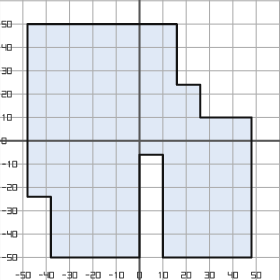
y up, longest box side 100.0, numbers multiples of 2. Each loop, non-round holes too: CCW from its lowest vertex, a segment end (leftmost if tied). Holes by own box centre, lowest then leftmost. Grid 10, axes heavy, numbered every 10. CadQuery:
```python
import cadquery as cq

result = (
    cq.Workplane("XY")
    .moveTo(-38.0, -50.0)
    .lineTo(0.0, -50.0)
    .lineTo(0.0, -6.0)
    .lineTo(10.0, -6.0)
    .lineTo(10.0, -50.0)
    .lineTo(48.0, -50.0)
    .lineTo(48.0, 10.0)
    .lineTo(26.0, 10.0)
    .lineTo(26.0, 24.0)
    .lineTo(16.0, 24.0)
    .lineTo(16.0, 50.0)
    .lineTo(-48.0, 50.0)
    .lineTo(-48.0, -24.0)
    .lineTo(-38.0, -24.0)
    .close()
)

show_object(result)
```